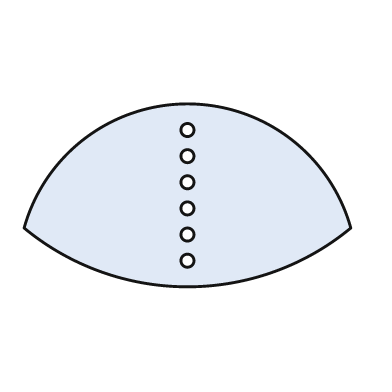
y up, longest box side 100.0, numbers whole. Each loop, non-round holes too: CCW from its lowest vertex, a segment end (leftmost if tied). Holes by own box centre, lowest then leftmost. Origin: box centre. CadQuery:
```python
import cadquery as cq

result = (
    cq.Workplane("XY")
    .moveTo(-50.0, -10.0)
    .threePointArc((0.0, -28.0), (50.0, -10.0))
    .threePointArc((0.0, 28.0), (-50.0, -10.0))
    .close()
    .moveTo(0.0, -20.0)
    .circle(2.0)
    .moveTo(0.0, -12.0)
    .circle(2.0)
    .moveTo(0.0, -4.0)
    .circle(2.0)
    .moveTo(0.0, 4.0)
    .circle(2.0)
    .moveTo(0.0, 12.0)
    .circle(2.0)
    .moveTo(0.0, 20.0)
    .circle(2.0)
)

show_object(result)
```